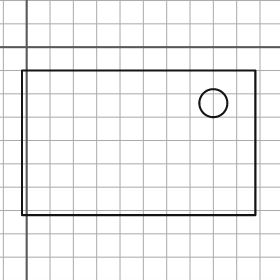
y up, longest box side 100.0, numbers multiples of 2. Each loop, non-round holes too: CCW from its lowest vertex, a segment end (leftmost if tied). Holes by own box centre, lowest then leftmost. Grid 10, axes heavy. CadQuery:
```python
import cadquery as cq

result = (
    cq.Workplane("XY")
    .moveTo(-2.0, -72.0)
    .lineTo(98.0, -72.0)
    .lineTo(98.0, -10.0)
    .lineTo(-2.0, -10.0)
    .close()
    .moveTo(80.0, -24.0)
    .circle(6.0)
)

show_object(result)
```